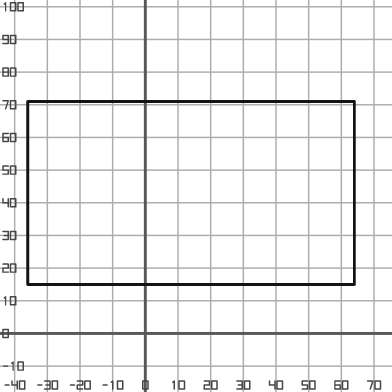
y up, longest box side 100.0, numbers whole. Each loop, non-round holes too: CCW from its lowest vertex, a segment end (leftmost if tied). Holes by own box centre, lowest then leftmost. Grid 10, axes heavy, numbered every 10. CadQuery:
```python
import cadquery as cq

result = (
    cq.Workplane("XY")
    .moveTo(-36.0, 15.0)
    .lineTo(64.0, 15.0)
    .lineTo(64.0, 71.0)
    .lineTo(-36.0, 71.0)
    .close()
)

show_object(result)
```